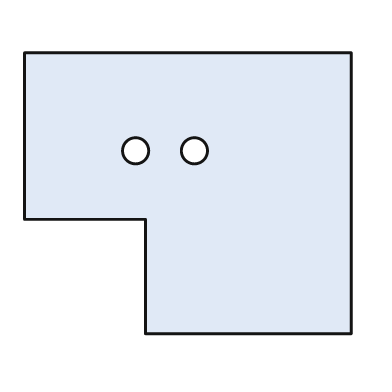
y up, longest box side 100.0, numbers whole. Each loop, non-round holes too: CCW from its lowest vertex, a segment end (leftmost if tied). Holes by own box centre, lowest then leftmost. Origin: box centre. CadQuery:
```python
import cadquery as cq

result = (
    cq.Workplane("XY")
    .moveTo(-13.0, -43.0)
    .lineTo(50.0, -43.0)
    .lineTo(50.0, 43.0)
    .lineTo(-50.0, 43.0)
    .lineTo(-50.0, -8.0)
    .lineTo(-13.0, -8.0)
    .close()
    .moveTo(-16.0, 13.0)
    .circle(4.0)
    .moveTo(2.0, 13.0)
    .circle(4.0)
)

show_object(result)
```